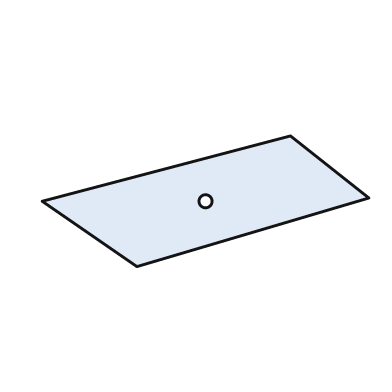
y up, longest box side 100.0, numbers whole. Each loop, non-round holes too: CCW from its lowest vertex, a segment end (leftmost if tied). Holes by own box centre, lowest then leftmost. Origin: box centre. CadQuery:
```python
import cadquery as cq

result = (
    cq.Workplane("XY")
    .moveTo(-21.0, -20.0)
    .lineTo(50.0, 1.0)
    .lineTo(26.0, 20.0)
    .lineTo(-50.0, 0.0)
    .close()
    .moveTo(0.0, 0.0)
    .circle(2.0)
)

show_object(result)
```